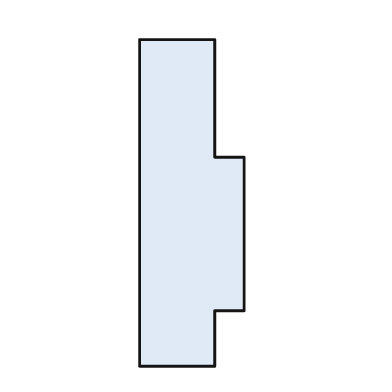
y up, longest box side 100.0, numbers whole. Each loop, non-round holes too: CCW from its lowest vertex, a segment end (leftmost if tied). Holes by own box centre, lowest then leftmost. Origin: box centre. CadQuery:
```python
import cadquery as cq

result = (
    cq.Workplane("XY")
    .moveTo(-16.0, -50.0)
    .lineTo(7.0, -50.0)
    .lineTo(7.0, -33.0)
    .lineTo(16.0, -33.0)
    .lineTo(16.0, 14.0)
    .lineTo(7.0, 14.0)
    .lineTo(7.0, 50.0)
    .lineTo(-16.0, 50.0)
    .close()
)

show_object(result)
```